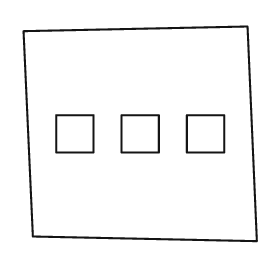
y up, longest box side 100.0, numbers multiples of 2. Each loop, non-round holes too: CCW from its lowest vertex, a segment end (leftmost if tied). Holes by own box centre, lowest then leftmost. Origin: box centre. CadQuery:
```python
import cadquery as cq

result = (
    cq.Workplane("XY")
    .moveTo(50.0, -46.0)
    .lineTo(46.0, 46.0)
    .lineTo(-50.0, 44.0)
    .lineTo(-46.0, -44.0)
    .close()
    .moveTo(-36.0, -8.0)
    .lineTo(-20.0, -8.0)
    .lineTo(-20.0, 8.0)
    .lineTo(-36.0, 8.0)
    .close()
    .moveTo(-8.0, -8.0)
    .lineTo(8.0, -8.0)
    .lineTo(8.0, 8.0)
    .lineTo(-8.0, 8.0)
    .close()
    .moveTo(20.0, -8.0)
    .lineTo(36.0, -8.0)
    .lineTo(36.0, 8.0)
    .lineTo(20.0, 8.0)
    .close()
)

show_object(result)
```